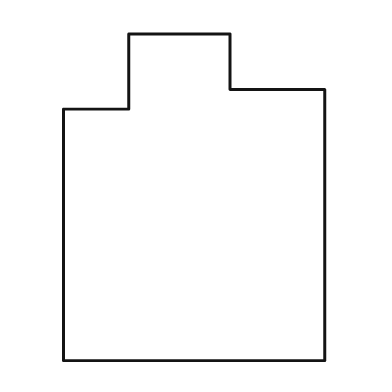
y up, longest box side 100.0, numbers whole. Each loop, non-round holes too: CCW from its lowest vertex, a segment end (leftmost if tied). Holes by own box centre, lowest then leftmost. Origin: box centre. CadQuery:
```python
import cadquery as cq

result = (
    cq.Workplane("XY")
    .moveTo(-40.0, -50.0)
    .lineTo(40.0, -50.0)
    .lineTo(40.0, 33.0)
    .lineTo(11.0, 33.0)
    .lineTo(11.0, 50.0)
    .lineTo(-20.0, 50.0)
    .lineTo(-20.0, 27.0)
    .lineTo(-40.0, 27.0)
    .close()
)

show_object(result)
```